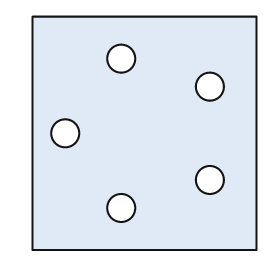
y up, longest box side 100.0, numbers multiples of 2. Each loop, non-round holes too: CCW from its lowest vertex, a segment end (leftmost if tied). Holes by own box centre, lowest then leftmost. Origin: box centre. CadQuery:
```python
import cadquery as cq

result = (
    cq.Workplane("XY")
    .moveTo(-48.0, -50.0)
    .lineTo(48.0, -50.0)
    .lineTo(48.0, 50.0)
    .lineTo(-48.0, 50.0)
    .close()
    .moveTo(-10.0, -32.0)
    .circle(6.0)
    .moveTo(28.0, -20.0)
    .circle(6.0)
    .moveTo(-34.0, 0.0)
    .circle(6.0)
    .moveTo(28.0, 20.0)
    .circle(6.0)
    .moveTo(-10.0, 32.0)
    .circle(6.0)
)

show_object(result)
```